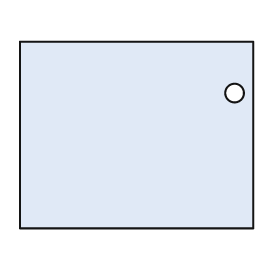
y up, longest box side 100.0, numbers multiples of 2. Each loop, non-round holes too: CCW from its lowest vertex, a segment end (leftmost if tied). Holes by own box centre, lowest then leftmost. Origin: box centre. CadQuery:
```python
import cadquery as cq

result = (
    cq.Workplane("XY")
    .moveTo(-50.0, -40.0)
    .lineTo(50.0, -40.0)
    .lineTo(50.0, 40.0)
    .lineTo(-50.0, 40.0)
    .close()
    .moveTo(42.0, 18.0)
    .circle(4.0)
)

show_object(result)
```